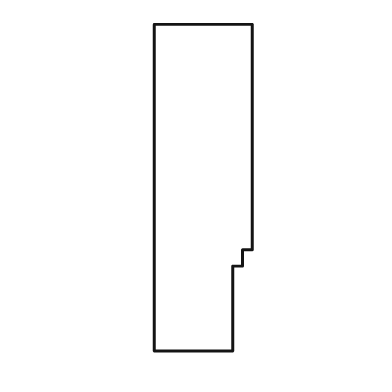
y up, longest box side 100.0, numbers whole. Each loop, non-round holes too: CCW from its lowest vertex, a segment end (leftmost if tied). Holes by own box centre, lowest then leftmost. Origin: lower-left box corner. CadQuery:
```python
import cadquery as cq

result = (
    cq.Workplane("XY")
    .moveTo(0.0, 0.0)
    .lineTo(24.0, 0.0)
    .lineTo(24.0, 26.0)
    .lineTo(27.0, 26.0)
    .lineTo(27.0, 31.0)
    .lineTo(30.0, 31.0)
    .lineTo(30.0, 100.0)
    .lineTo(0.0, 100.0)
    .close()
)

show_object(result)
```